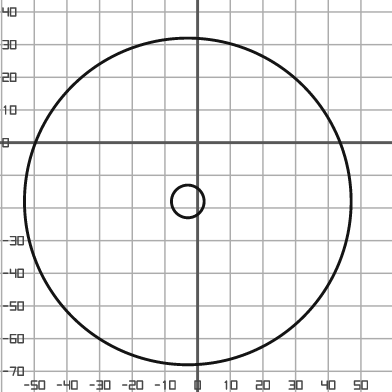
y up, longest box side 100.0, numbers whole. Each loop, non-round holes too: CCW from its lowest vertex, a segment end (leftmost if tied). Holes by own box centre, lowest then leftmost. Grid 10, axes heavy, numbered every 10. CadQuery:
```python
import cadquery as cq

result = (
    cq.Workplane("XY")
    .moveTo(-3.0, -18.0)
    .circle(50.0)
    .moveTo(-3.0, -18.0)
    .circle(5.0)
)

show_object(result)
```